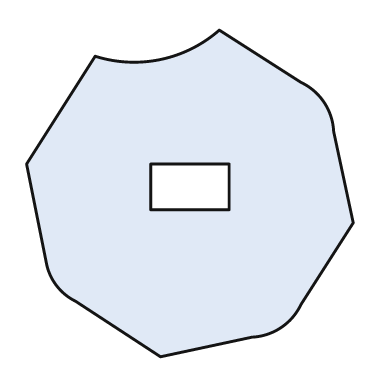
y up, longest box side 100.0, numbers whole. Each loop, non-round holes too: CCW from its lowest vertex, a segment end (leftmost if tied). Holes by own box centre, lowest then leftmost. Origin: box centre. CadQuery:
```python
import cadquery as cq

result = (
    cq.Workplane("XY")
    .moveTo(-9.0, -50.0)
    .lineTo(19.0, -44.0)
    .threePointArc((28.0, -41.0), (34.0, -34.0))
    .lineTo(50.0, -9.0)
    .lineTo(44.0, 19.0)
    .threePointArc((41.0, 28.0), (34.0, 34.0))
    .lineTo(9.0, 50.0)
    .threePointArc((-9.0, 41.0), (-29.0, 42.0))
    .lineTo(-50.0, 9.0)
    .lineTo(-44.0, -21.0)
    .threePointArc((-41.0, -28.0), (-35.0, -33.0))
    .close()
    .moveTo(-12.0, -5.0)
    .lineTo(12.0, -5.0)
    .lineTo(12.0, 9.0)
    .lineTo(-12.0, 9.0)
    .close()
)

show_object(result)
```